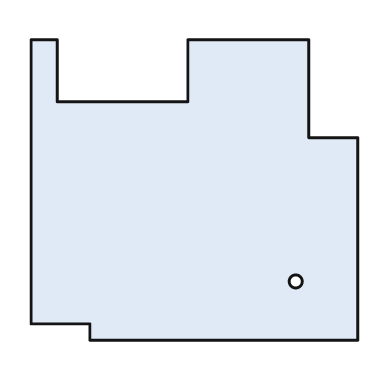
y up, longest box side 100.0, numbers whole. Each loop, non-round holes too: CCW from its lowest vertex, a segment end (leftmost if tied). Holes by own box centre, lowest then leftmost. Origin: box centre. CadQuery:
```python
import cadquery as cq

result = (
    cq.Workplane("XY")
    .moveTo(-32.0, -46.0)
    .lineTo(50.0, -46.0)
    .lineTo(50.0, 16.0)
    .lineTo(35.0, 16.0)
    .lineTo(35.0, 46.0)
    .lineTo(-2.0, 46.0)
    .lineTo(-2.0, 27.0)
    .lineTo(-42.0, 27.0)
    .lineTo(-42.0, 46.0)
    .lineTo(-50.0, 46.0)
    .lineTo(-50.0, -41.0)
    .lineTo(-32.0, -41.0)
    .close()
    .moveTo(31.0, -28.0)
    .circle(2.0)
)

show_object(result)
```